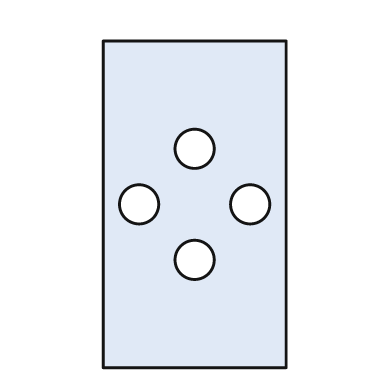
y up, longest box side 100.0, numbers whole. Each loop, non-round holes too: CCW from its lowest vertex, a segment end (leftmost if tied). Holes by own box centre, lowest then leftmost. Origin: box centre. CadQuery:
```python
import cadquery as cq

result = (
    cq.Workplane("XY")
    .moveTo(-28.0, -50.0)
    .lineTo(28.0, -50.0)
    .lineTo(28.0, 50.0)
    .lineTo(-28.0, 50.0)
    .close()
    .moveTo(0.0, -17.0)
    .circle(6.0)
    .moveTo(-17.0, 0.0)
    .circle(6.0)
    .moveTo(17.0, 0.0)
    .circle(6.0)
    .moveTo(0.0, 17.0)
    .circle(6.0)
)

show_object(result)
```